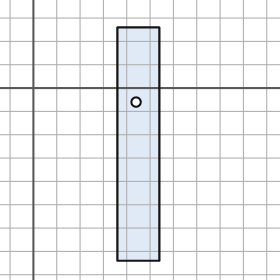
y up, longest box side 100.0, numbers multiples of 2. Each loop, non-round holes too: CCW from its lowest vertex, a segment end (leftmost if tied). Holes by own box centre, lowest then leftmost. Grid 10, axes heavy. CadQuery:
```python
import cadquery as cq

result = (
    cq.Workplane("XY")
    .moveTo(36.0, -74.0)
    .lineTo(54.0, -74.0)
    .lineTo(54.0, 26.0)
    .lineTo(36.0, 26.0)
    .close()
    .moveTo(44.0, -6.0)
    .circle(2.0)
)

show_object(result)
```